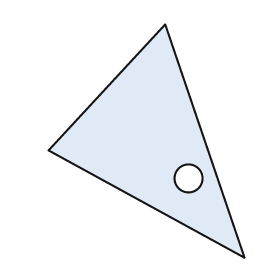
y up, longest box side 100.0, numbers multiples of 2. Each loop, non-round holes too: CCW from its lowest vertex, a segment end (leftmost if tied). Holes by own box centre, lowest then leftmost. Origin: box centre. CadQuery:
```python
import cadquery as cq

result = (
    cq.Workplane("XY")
    .moveTo(42.0, -50.0)
    .lineTo(8.0, 50.0)
    .lineTo(-42.0, -4.0)
    .close()
    .moveTo(18.0, -16.0)
    .circle(6.0)
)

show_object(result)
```